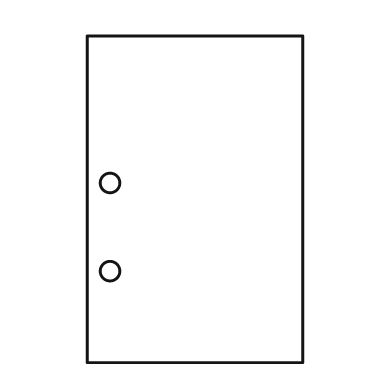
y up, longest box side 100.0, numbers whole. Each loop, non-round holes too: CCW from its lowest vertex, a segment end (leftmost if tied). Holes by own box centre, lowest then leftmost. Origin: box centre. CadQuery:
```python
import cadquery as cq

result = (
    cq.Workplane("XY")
    .moveTo(-33.0, -50.0)
    .lineTo(33.0, -50.0)
    .lineTo(33.0, 50.0)
    .lineTo(-33.0, 50.0)
    .close()
    .moveTo(-26.0, -22.0)
    .circle(3.0)
    .moveTo(-26.0, 5.0)
    .circle(3.0)
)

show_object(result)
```